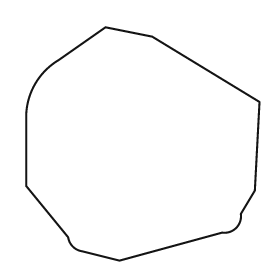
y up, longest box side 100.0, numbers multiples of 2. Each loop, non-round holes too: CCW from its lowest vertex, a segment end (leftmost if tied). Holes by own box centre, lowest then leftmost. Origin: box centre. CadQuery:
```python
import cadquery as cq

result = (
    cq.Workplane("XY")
    .moveTo(-10.0, -50.0)
    .lineTo(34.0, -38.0)
    .threePointArc((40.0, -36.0), (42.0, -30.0))
    .lineTo(48.0, -20.0)
    .lineTo(50.0, 18.0)
    .lineTo(4.0, 46.0)
    .lineTo(-16.0, 50.0)
    .lineTo(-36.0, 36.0)
    .threePointArc((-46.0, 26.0), (-50.0, 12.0))
    .lineTo(-50.0, -18.0)
    .lineTo(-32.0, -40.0)
    .threePointArc((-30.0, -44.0), (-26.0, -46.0))
    .close()
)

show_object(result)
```